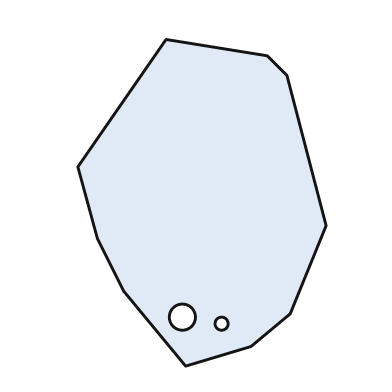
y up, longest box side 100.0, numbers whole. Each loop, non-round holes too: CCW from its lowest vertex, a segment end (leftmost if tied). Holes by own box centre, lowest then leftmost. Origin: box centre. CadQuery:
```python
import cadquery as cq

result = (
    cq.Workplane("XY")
    .moveTo(-5.0, -50.0)
    .lineTo(15.0, -44.0)
    .lineTo(27.0, -34.0)
    .lineTo(38.0, -7.0)
    .lineTo(26.0, 39.0)
    .lineTo(20.0, 45.0)
    .lineTo(-11.0, 50.0)
    .lineTo(-38.0, 11.0)
    .lineTo(-32.0, -11.0)
    .lineTo(-24.0, -27.0)
    .close()
    .moveTo(6.0, -37.0)
    .circle(2.0)
    .moveTo(-6.0, -35.0)
    .circle(4.0)
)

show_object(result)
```